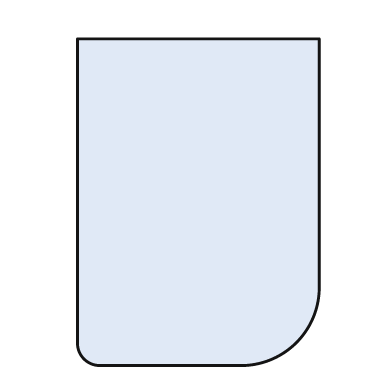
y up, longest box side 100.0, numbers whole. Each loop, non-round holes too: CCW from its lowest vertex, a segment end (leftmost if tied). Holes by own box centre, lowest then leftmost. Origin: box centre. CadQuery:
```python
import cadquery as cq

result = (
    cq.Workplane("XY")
    .moveTo(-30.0, -50.0)
    .lineTo(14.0, -50.0)
    .threePointArc((30.0, -43.0), (37.0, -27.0))
    .lineTo(37.0, 50.0)
    .lineTo(-37.0, 50.0)
    .lineTo(-37.0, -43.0)
    .threePointArc((-35.0, -48.0), (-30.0, -50.0))
    .close()
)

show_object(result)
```